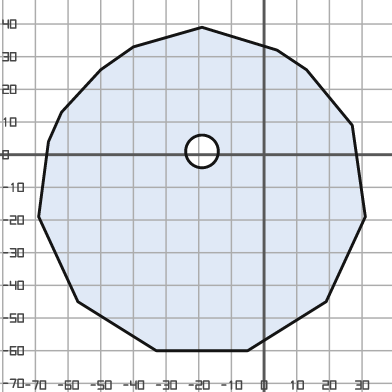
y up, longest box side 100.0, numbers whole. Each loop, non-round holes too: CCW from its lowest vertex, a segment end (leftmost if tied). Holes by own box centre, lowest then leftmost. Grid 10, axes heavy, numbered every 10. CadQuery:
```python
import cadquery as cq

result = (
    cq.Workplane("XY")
    .moveTo(-33.0, -60.0)
    .lineTo(-5.0, -60.0)
    .lineTo(19.0, -45.0)
    .lineTo(31.0, -19.0)
    .lineTo(27.0, 9.0)
    .lineTo(13.0, 26.0)
    .lineTo(4.0, 32.0)
    .lineTo(-19.0, 39.0)
    .lineTo(-40.0, 33.0)
    .lineTo(-50.0, 26.0)
    .lineTo(-62.0, 13.0)
    .lineTo(-66.0, 4.0)
    .lineTo(-69.0, -19.0)
    .lineTo(-57.0, -45.0)
    .close()
    .moveTo(-19.0, 1.0)
    .circle(5.0)
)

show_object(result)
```